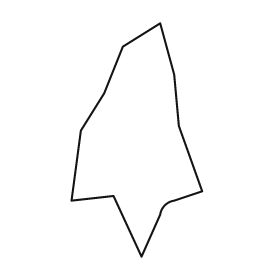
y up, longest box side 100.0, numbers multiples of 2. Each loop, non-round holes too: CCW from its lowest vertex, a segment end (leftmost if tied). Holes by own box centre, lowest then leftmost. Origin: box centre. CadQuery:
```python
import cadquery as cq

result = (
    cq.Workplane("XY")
    .moveTo(2.0, -50.0)
    .lineTo(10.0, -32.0)
    .threePointArc((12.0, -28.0), (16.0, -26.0))
    .lineTo(28.0, -22.0)
    .lineTo(18.0, 6.0)
    .lineTo(16.0, 28.0)
    .lineTo(10.0, 50.0)
    .lineTo(-6.0, 40.0)
    .lineTo(-14.0, 20.0)
    .lineTo(-24.0, 4.0)
    .lineTo(-28.0, -26.0)
    .lineTo(-10.0, -24.0)
    .close()
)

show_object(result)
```